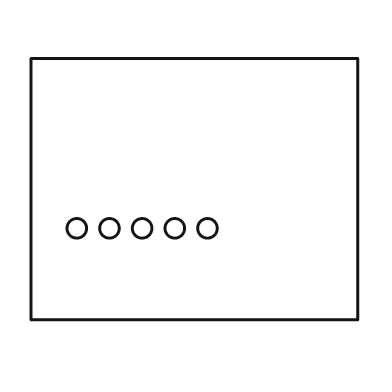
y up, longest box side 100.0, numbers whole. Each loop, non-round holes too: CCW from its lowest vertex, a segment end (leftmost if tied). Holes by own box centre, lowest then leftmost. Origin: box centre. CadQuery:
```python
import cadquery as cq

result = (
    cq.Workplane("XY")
    .moveTo(-50.0, -40.0)
    .lineTo(50.0, -40.0)
    .lineTo(50.0, 40.0)
    .lineTo(-50.0, 40.0)
    .close()
    .moveTo(-36.0, -12.0)
    .circle(3.0)
    .moveTo(-26.0, -12.0)
    .circle(3.0)
    .moveTo(-16.0, -12.0)
    .circle(3.0)
    .moveTo(-6.0, -12.0)
    .circle(3.0)
    .moveTo(4.0, -12.0)
    .circle(3.0)
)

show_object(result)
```